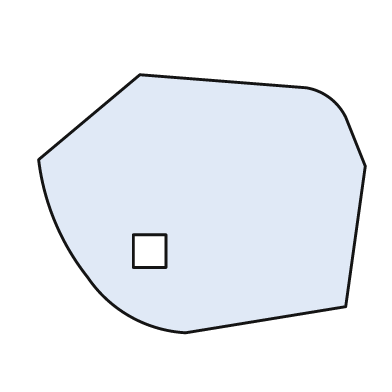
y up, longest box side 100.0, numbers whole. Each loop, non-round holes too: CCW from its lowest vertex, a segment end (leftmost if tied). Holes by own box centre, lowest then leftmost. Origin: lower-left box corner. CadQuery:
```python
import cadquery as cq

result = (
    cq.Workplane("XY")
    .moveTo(45.0, 0.0)
    .lineTo(94.0, 8.0)
    .lineTo(100.0, 51.0)
    .lineTo(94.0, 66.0)
    .threePointArc((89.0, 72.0), (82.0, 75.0))
    .lineTo(31.0, 79.0)
    .lineTo(0.0, 53.0)
    .threePointArc((5.0, 34.0), (15.0, 17.0))
    .threePointArc((28.0, 5.0), (45.0, 0.0))
    .close()
    .moveTo(29.0, 20.0)
    .lineTo(39.0, 20.0)
    .lineTo(39.0, 30.0)
    .lineTo(29.0, 30.0)
    .close()
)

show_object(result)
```